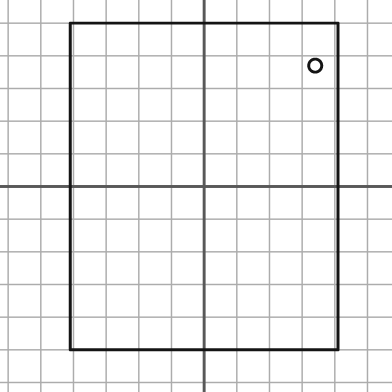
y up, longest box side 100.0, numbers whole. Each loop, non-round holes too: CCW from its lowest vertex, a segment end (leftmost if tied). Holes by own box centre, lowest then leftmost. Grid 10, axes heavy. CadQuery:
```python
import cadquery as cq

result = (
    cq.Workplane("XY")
    .moveTo(-41.0, -50.0)
    .lineTo(41.0, -50.0)
    .lineTo(41.0, 50.0)
    .lineTo(-41.0, 50.0)
    .close()
    .moveTo(34.0, 37.0)
    .circle(2.0)
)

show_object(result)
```